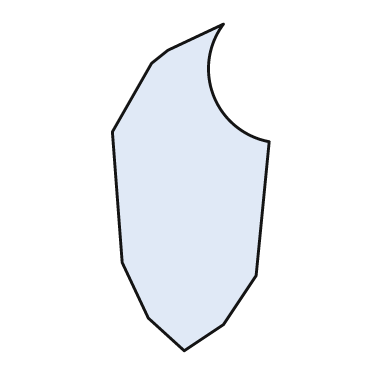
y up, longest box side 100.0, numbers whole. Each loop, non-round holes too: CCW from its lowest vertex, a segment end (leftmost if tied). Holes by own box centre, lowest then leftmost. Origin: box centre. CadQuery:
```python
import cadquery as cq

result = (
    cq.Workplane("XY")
    .moveTo(-2.0, -50.0)
    .lineTo(10.0, -42.0)
    .lineTo(20.0, -27.0)
    .lineTo(24.0, 14.0)
    .threePointArc((7.0, 28.0), (10.0, 50.0))
    .lineTo(-7.0, 42.0)
    .lineTo(-12.0, 38.0)
    .lineTo(-24.0, 17.0)
    .lineTo(-21.0, -23.0)
    .lineTo(-13.0, -40.0)
    .close()
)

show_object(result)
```